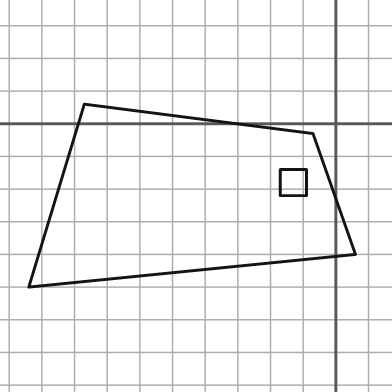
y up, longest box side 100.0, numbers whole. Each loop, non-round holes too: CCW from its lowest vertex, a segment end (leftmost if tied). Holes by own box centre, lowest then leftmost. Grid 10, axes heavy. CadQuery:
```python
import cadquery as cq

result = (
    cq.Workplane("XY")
    .moveTo(-94.0, -50.0)
    .lineTo(6.0, -40.0)
    .lineTo(-7.0, -3.0)
    .lineTo(-77.0, 6.0)
    .close()
    .moveTo(-17.0, -22.0)
    .lineTo(-9.0, -22.0)
    .lineTo(-9.0, -14.0)
    .lineTo(-17.0, -14.0)
    .close()
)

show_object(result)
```